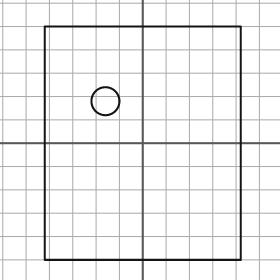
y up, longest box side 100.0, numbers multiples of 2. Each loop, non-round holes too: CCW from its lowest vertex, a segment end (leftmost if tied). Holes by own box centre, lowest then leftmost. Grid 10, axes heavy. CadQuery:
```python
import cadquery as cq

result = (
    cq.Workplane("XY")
    .moveTo(-42.0, -50.0)
    .lineTo(42.0, -50.0)
    .lineTo(42.0, 50.0)
    .lineTo(-42.0, 50.0)
    .close()
    .moveTo(-16.0, 18.0)
    .circle(6.0)
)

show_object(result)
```